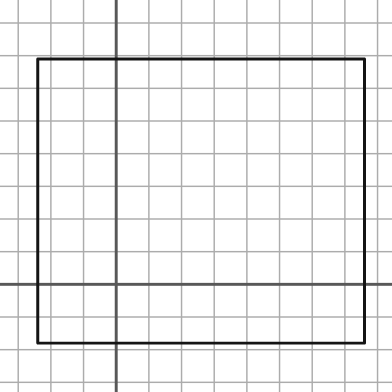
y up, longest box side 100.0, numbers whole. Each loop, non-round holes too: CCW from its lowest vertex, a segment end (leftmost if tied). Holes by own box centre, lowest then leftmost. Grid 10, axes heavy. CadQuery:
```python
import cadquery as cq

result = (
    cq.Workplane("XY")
    .moveTo(-24.0, -18.0)
    .lineTo(76.0, -18.0)
    .lineTo(76.0, 69.0)
    .lineTo(-24.0, 69.0)
    .close()
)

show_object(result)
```